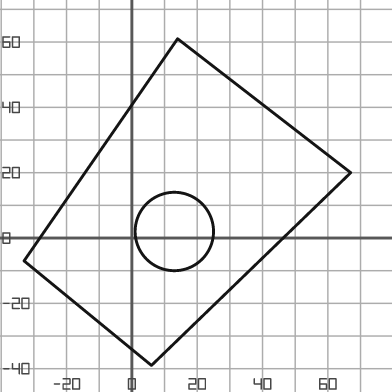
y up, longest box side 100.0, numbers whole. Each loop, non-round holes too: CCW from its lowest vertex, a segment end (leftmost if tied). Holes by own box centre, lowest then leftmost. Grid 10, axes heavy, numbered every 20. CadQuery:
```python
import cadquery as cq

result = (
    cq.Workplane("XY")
    .moveTo(6.0, -39.0)
    .lineTo(67.0, 20.0)
    .lineTo(14.0, 61.0)
    .lineTo(-33.0, -7.0)
    .close()
    .moveTo(13.0, 2.0)
    .circle(12.0)
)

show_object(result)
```